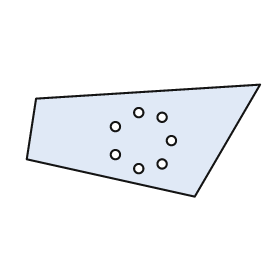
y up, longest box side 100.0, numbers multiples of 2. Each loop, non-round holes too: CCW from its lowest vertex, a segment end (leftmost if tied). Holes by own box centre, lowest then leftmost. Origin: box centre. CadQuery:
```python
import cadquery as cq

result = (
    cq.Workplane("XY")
    .moveTo(22.0, -24.0)
    .lineTo(50.0, 24.0)
    .lineTo(-46.0, 18.0)
    .lineTo(-50.0, -8.0)
    .close()
    .moveTo(-2.0, -12.0)
    .circle(2.0)
    .moveTo(8.0, -10.0)
    .circle(2.0)
    .moveTo(-12.0, -6.0)
    .circle(2.0)
    .moveTo(12.0, 0.0)
    .circle(2.0)
    .moveTo(-12.0, 6.0)
    .circle(2.0)
    .moveTo(8.0, 10.0)
    .circle(2.0)
    .moveTo(-2.0, 12.0)
    .circle(2.0)
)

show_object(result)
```